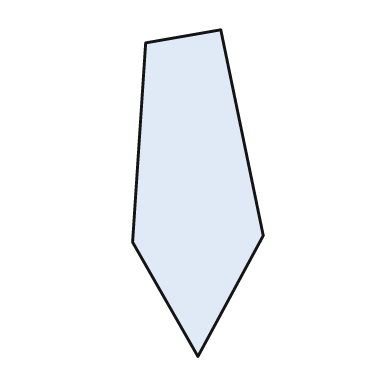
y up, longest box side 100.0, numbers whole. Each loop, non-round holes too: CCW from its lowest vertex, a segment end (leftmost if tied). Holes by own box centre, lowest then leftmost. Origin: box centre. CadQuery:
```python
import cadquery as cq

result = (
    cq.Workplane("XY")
    .moveTo(0.0, -50.0)
    .lineTo(20.0, -13.0)
    .lineTo(7.0, 50.0)
    .lineTo(-16.0, 46.0)
    .lineTo(-20.0, -15.0)
    .close()
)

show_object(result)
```